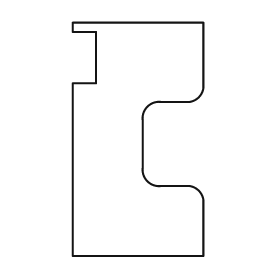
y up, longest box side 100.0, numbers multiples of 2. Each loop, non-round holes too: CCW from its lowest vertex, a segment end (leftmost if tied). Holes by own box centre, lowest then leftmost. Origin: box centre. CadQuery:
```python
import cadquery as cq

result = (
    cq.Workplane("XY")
    .moveTo(-28.0, -50.0)
    .lineTo(28.0, -50.0)
    .lineTo(28.0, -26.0)
    .threePointArc((26.0, -22.0), (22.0, -20.0))
    .lineTo(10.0, -20.0)
    .threePointArc((4.0, -18.0), (2.0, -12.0))
    .lineTo(2.0, 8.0)
    .threePointArc((4.0, 14.0), (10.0, 16.0))
    .lineTo(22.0, 16.0)
    .threePointArc((26.0, 18.0), (28.0, 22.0))
    .lineTo(28.0, 50.0)
    .lineTo(-28.0, 50.0)
    .lineTo(-28.0, 46.0)
    .lineTo(-18.0, 46.0)
    .lineTo(-18.0, 24.0)
    .lineTo(-28.0, 24.0)
    .close()
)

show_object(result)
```